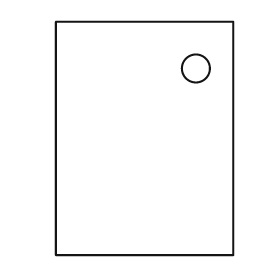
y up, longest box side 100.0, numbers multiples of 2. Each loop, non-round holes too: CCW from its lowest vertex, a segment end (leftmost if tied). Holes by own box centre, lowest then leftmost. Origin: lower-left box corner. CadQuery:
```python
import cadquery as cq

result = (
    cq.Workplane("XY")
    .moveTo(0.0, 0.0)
    .lineTo(76.0, 0.0)
    .lineTo(76.0, 100.0)
    .lineTo(0.0, 100.0)
    .close()
    .moveTo(60.0, 80.0)
    .circle(6.0)
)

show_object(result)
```